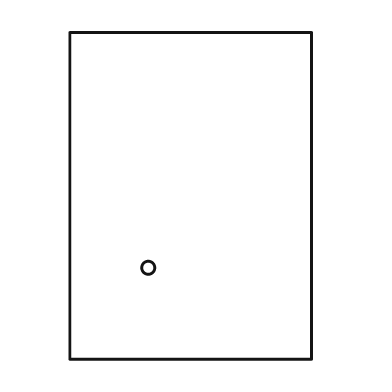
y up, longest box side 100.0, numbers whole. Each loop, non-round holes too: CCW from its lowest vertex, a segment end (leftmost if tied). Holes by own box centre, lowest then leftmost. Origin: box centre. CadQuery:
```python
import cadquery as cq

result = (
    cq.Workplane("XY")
    .moveTo(-37.0, -50.0)
    .lineTo(37.0, -50.0)
    .lineTo(37.0, 50.0)
    .lineTo(-37.0, 50.0)
    .close()
    .moveTo(-13.0, -22.0)
    .circle(2.0)
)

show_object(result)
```